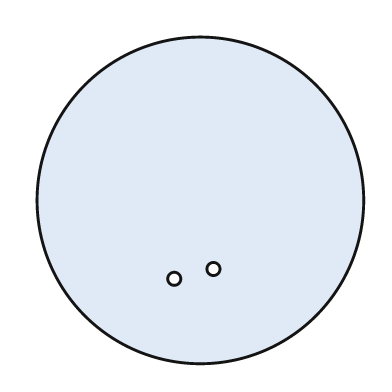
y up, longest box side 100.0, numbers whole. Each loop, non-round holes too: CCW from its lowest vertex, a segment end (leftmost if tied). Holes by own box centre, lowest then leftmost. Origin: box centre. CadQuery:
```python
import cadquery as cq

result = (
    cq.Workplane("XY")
    .moveTo(0.0, 0.0)
    .circle(50.0)
    .moveTo(-8.0, -24.0)
    .circle(2.0)
    .moveTo(4.0, -21.0)
    .circle(2.0)
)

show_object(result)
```